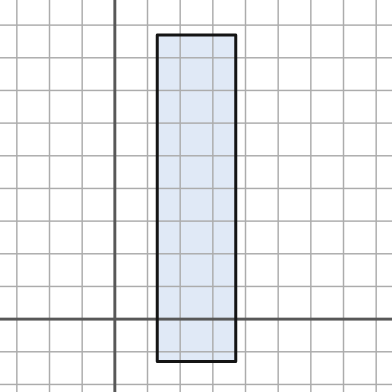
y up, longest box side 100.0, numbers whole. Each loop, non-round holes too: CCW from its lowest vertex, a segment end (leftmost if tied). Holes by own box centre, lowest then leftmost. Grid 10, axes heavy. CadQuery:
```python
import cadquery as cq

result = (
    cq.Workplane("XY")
    .moveTo(13.0, -13.0)
    .lineTo(37.0, -13.0)
    .lineTo(37.0, 87.0)
    .lineTo(13.0, 87.0)
    .close()
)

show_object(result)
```